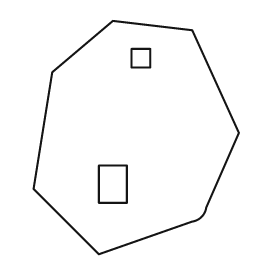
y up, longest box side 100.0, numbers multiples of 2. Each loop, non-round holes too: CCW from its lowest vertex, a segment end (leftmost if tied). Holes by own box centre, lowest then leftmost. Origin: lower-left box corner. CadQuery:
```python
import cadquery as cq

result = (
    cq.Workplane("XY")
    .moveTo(28.0, 0.0)
    .lineTo(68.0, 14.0)
    .threePointArc((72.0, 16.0), (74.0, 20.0))
    .lineTo(88.0, 52.0)
    .lineTo(68.0, 96.0)
    .lineTo(34.0, 100.0)
    .lineTo(8.0, 78.0)
    .lineTo(0.0, 28.0)
    .close()
    .moveTo(28.0, 22.0)
    .lineTo(40.0, 22.0)
    .lineTo(40.0, 38.0)
    .lineTo(28.0, 38.0)
    .close()
    .moveTo(42.0, 80.0)
    .lineTo(50.0, 80.0)
    .lineTo(50.0, 88.0)
    .lineTo(42.0, 88.0)
    .close()
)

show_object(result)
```